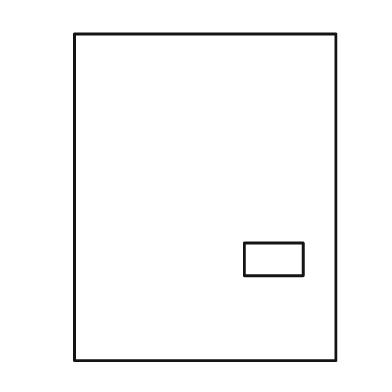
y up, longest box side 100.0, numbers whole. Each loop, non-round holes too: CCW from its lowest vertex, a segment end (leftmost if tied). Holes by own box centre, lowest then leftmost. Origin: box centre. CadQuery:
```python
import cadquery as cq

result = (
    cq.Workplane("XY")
    .moveTo(-40.0, -50.0)
    .lineTo(40.0, -50.0)
    .lineTo(40.0, 50.0)
    .lineTo(-40.0, 50.0)
    .close()
    .moveTo(12.0, -24.0)
    .lineTo(30.0, -24.0)
    .lineTo(30.0, -14.0)
    .lineTo(12.0, -14.0)
    .close()
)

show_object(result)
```